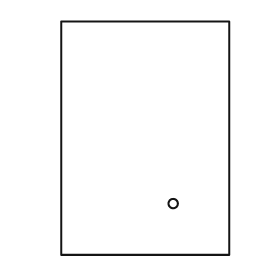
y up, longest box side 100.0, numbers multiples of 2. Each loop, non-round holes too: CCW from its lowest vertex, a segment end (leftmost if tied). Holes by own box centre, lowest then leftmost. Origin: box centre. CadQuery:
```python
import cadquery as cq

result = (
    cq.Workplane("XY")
    .moveTo(-36.0, -50.0)
    .lineTo(36.0, -50.0)
    .lineTo(36.0, 50.0)
    .lineTo(-36.0, 50.0)
    .close()
    .moveTo(12.0, -28.0)
    .circle(2.0)
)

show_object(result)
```